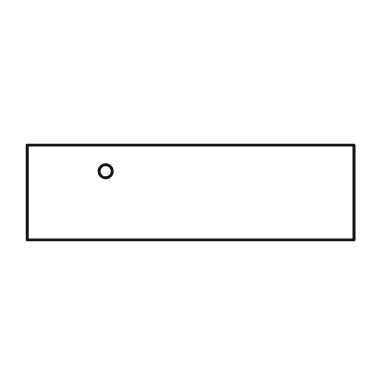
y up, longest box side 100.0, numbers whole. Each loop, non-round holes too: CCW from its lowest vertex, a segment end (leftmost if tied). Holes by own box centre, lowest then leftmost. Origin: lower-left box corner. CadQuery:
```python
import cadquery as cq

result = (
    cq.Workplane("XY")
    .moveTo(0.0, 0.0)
    .lineTo(100.0, 0.0)
    .lineTo(100.0, 29.0)
    .lineTo(0.0, 29.0)
    .close()
    .moveTo(24.0, 21.0)
    .circle(2.0)
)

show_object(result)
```